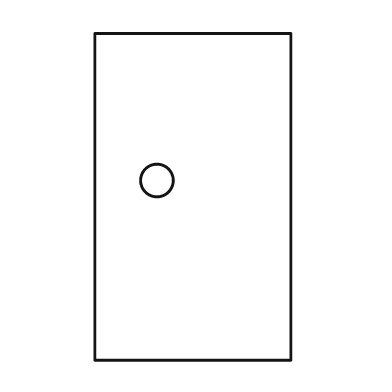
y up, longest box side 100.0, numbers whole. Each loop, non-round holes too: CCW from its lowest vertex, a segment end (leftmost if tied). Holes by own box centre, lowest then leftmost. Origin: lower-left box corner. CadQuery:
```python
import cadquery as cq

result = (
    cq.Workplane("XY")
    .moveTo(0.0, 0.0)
    .lineTo(60.0, 0.0)
    .lineTo(60.0, 100.0)
    .lineTo(0.0, 100.0)
    .close()
    .moveTo(19.0, 55.0)
    .circle(5.0)
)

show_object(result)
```